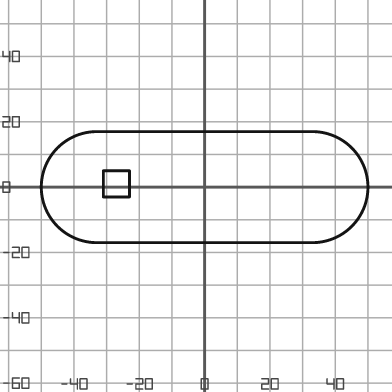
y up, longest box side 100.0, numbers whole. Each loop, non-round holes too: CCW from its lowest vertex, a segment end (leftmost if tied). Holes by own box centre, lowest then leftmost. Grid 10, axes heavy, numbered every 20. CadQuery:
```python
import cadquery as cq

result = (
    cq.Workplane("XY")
    .moveTo(-33.0, -17.0)
    .lineTo(33.0, -17.0)
    .threePointArc((50.0, 0.0), (33.0, 17.0))
    .lineTo(-33.0, 17.0)
    .threePointArc((-50.0, 0.0), (-33.0, -17.0))
    .close()
    .moveTo(-31.0, -3.0)
    .lineTo(-23.0, -3.0)
    .lineTo(-23.0, 5.0)
    .lineTo(-31.0, 5.0)
    .close()
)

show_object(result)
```